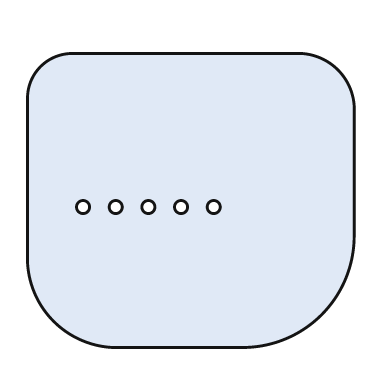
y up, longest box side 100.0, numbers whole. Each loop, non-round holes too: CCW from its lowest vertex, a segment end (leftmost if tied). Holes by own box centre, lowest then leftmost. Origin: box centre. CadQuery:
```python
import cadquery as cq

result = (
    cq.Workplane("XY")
    .moveTo(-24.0, -45.0)
    .lineTo(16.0, -45.0)
    .threePointArc((40.0, -35.0), (50.0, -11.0))
    .lineTo(50.0, 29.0)
    .threePointArc((45.0, 40.0), (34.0, 45.0))
    .lineTo(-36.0, 45.0)
    .threePointArc((-46.0, 41.0), (-50.0, 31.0))
    .lineTo(-50.0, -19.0)
    .threePointArc((-42.0, -37.0), (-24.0, -45.0))
    .close()
    .moveTo(-33.0, -2.0)
    .circle(2.0)
    .moveTo(-23.0, -2.0)
    .circle(2.0)
    .moveTo(-13.0, -2.0)
    .circle(2.0)
    .moveTo(-3.0, -2.0)
    .circle(2.0)
    .moveTo(7.0, -2.0)
    .circle(2.0)
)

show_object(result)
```